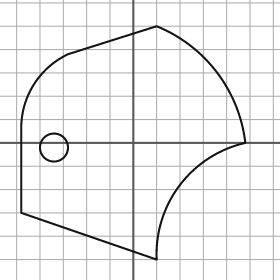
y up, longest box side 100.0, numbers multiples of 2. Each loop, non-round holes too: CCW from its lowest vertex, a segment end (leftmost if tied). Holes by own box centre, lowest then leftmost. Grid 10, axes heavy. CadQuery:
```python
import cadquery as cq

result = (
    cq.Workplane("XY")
    .moveTo(10.0, -50.0)
    .threePointArc((20.0, -18.0), (48.0, 0.0))
    .threePointArc((36.0, 30.0), (10.0, 50.0))
    .lineTo(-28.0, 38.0)
    .threePointArc((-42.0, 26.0), (-48.0, 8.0))
    .lineTo(-48.0, -30.0)
    .close()
    .moveTo(-34.0, -2.0)
    .circle(6.0)
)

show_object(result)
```